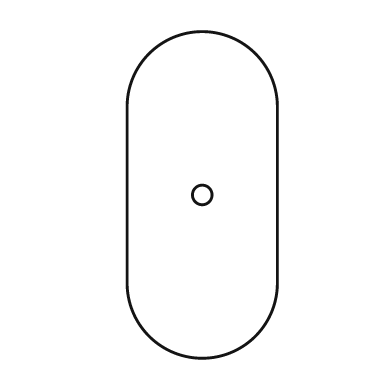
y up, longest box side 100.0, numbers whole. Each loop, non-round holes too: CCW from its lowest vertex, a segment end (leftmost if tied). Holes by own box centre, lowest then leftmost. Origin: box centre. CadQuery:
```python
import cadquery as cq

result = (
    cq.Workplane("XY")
    .moveTo(-23.0, -27.0)
    .threePointArc((0.0, -50.0), (23.0, -27.0))
    .lineTo(23.0, 27.0)
    .threePointArc((0.0, 50.0), (-23.0, 27.0))
    .close()
    .moveTo(0.0, 0.0)
    .circle(3.0)
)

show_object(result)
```